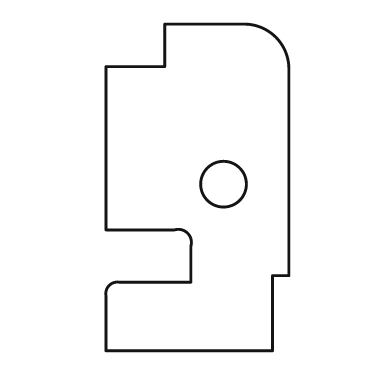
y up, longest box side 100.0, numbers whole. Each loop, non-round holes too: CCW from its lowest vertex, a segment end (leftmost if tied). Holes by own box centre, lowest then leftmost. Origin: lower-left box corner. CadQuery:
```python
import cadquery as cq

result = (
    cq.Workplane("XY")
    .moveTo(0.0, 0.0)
    .lineTo(51.0, 0.0)
    .lineTo(51.0, 23.0)
    .lineTo(56.0, 23.0)
    .lineTo(56.0, 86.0)
    .threePointArc((52.0, 96.0), (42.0, 100.0))
    .lineTo(18.0, 100.0)
    .lineTo(18.0, 87.0)
    .lineTo(0.0, 87.0)
    .lineTo(0.0, 37.0)
    .lineTo(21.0, 37.0)
    .threePointArc((25.0, 36.0), (26.0, 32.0))
    .lineTo(26.0, 21.0)
    .lineTo(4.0, 21.0)
    .threePointArc((1.0, 20.0), (0.0, 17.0))
    .close()
    .moveTo(36.0, 51.0)
    .circle(7.0)
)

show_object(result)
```